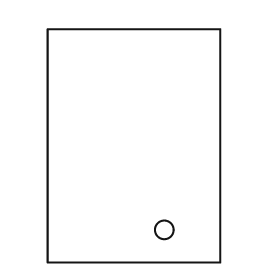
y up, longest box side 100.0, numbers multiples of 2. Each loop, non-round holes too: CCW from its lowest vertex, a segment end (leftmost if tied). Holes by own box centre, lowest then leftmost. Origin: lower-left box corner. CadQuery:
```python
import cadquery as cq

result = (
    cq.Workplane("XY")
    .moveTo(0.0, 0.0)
    .lineTo(74.0, 0.0)
    .lineTo(74.0, 100.0)
    .lineTo(0.0, 100.0)
    .close()
    .moveTo(50.0, 14.0)
    .circle(4.0)
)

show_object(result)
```